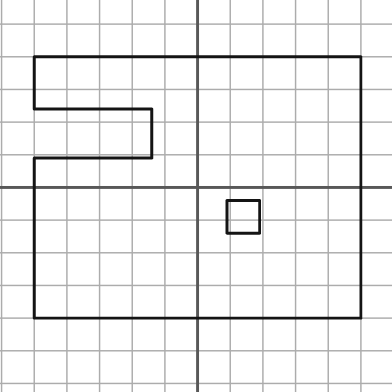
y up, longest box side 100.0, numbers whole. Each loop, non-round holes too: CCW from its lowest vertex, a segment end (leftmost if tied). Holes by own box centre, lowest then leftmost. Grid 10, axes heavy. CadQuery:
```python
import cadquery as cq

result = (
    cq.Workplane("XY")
    .moveTo(-50.0, -40.0)
    .lineTo(50.0, -40.0)
    .lineTo(50.0, 40.0)
    .lineTo(-50.0, 40.0)
    .lineTo(-50.0, 24.0)
    .lineTo(-14.0, 24.0)
    .lineTo(-14.0, 9.0)
    .lineTo(-50.0, 9.0)
    .close()
    .moveTo(9.0, -14.0)
    .lineTo(19.0, -14.0)
    .lineTo(19.0, -4.0)
    .lineTo(9.0, -4.0)
    .close()
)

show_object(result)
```